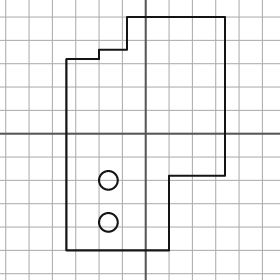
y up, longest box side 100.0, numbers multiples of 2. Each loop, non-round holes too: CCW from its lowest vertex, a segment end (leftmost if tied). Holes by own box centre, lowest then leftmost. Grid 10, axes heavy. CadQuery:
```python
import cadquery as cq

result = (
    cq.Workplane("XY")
    .moveTo(-34.0, -50.0)
    .lineTo(10.0, -50.0)
    .lineTo(10.0, -18.0)
    .lineTo(34.0, -18.0)
    .lineTo(34.0, 50.0)
    .lineTo(-8.0, 50.0)
    .lineTo(-8.0, 36.0)
    .lineTo(-20.0, 36.0)
    .lineTo(-20.0, 32.0)
    .lineTo(-34.0, 32.0)
    .close()
    .moveTo(-16.0, -38.0)
    .circle(4.0)
    .moveTo(-16.0, -20.0)
    .circle(4.0)
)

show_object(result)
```